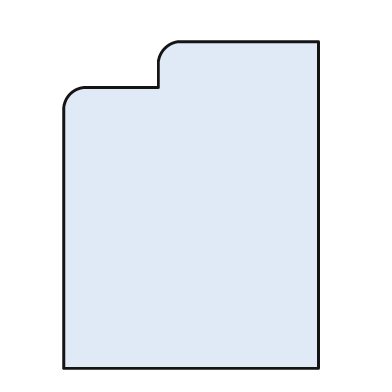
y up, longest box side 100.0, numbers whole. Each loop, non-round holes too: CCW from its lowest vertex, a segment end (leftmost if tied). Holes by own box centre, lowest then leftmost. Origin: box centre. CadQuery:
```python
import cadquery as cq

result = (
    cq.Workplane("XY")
    .moveTo(-39.0, -50.0)
    .lineTo(39.0, -50.0)
    .lineTo(39.0, 50.0)
    .lineTo(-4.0, 50.0)
    .threePointArc((-8.0, 48.0), (-10.0, 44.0))
    .lineTo(-10.0, 36.0)
    .lineTo(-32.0, 36.0)
    .threePointArc((-37.0, 34.0), (-39.0, 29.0))
    .close()
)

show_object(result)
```